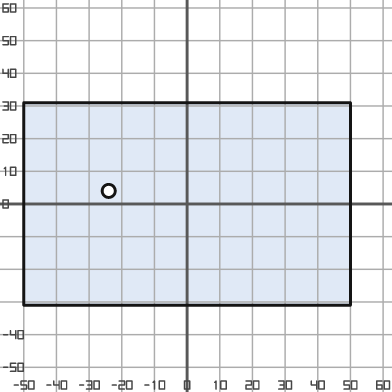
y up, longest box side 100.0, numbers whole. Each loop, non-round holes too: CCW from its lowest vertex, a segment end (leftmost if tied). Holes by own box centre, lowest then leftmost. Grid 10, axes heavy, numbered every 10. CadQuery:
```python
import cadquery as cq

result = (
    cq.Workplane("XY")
    .moveTo(-50.0, -31.0)
    .lineTo(50.0, -31.0)
    .lineTo(50.0, 31.0)
    .lineTo(-50.0, 31.0)
    .close()
    .moveTo(-24.0, 4.0)
    .circle(2.0)
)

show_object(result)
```